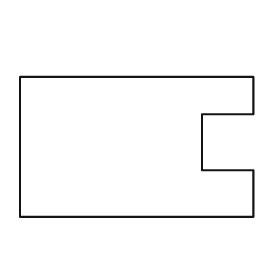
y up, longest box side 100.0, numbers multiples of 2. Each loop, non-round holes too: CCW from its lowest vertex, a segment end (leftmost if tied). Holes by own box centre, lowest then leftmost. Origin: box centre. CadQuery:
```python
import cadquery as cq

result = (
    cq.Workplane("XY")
    .moveTo(-50.0, -30.0)
    .lineTo(50.0, -30.0)
    .lineTo(50.0, -10.0)
    .lineTo(28.0, -10.0)
    .lineTo(28.0, 14.0)
    .lineTo(50.0, 14.0)
    .lineTo(50.0, 30.0)
    .lineTo(-50.0, 30.0)
    .close()
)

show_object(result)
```